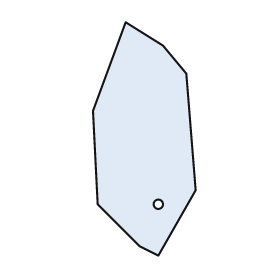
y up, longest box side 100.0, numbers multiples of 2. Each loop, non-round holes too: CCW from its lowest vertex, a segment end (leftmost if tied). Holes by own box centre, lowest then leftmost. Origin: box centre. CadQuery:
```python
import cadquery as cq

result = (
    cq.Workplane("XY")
    .moveTo(6.0, -50.0)
    .lineTo(22.0, -22.0)
    .lineTo(18.0, 28.0)
    .lineTo(8.0, 40.0)
    .lineTo(-8.0, 50.0)
    .lineTo(-22.0, 12.0)
    .lineTo(-20.0, -28.0)
    .lineTo(-2.0, -46.0)
    .close()
    .moveTo(6.0, -28.0)
    .circle(2.0)
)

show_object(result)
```